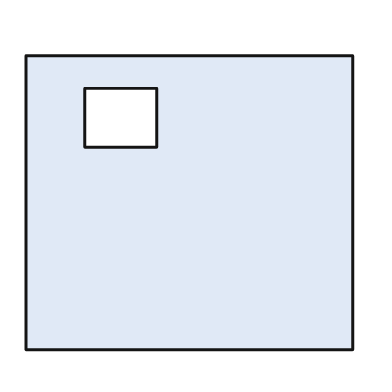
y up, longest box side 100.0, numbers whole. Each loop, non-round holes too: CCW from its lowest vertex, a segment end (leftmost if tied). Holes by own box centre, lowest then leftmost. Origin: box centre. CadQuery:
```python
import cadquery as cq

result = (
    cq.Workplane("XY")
    .moveTo(-50.0, -45.0)
    .lineTo(50.0, -45.0)
    .lineTo(50.0, 45.0)
    .lineTo(-50.0, 45.0)
    .close()
    .moveTo(-32.0, 17.0)
    .lineTo(-10.0, 17.0)
    .lineTo(-10.0, 35.0)
    .lineTo(-32.0, 35.0)
    .close()
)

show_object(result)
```